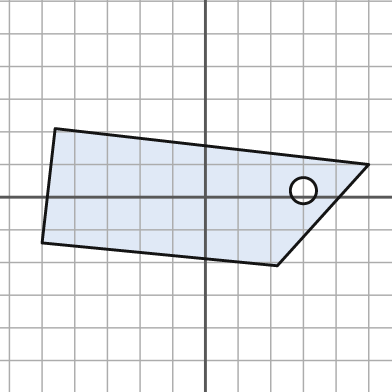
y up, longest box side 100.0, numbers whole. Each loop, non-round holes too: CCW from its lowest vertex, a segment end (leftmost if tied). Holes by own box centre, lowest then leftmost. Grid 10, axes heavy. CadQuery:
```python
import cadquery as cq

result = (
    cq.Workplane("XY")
    .moveTo(22.0, -21.0)
    .lineTo(50.0, 10.0)
    .lineTo(-46.0, 21.0)
    .lineTo(-50.0, -14.0)
    .close()
    .moveTo(30.0, 2.0)
    .circle(4.0)
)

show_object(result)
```